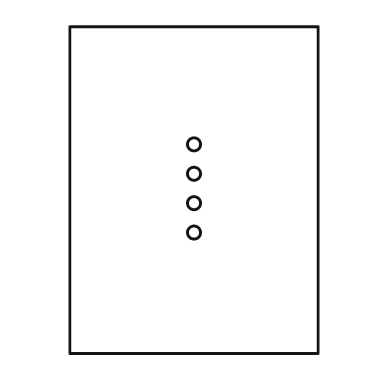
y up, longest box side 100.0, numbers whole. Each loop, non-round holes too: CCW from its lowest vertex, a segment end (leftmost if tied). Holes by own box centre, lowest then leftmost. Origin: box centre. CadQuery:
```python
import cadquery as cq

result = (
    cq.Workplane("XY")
    .moveTo(-38.0, -50.0)
    .lineTo(38.0, -50.0)
    .lineTo(38.0, 50.0)
    .lineTo(-38.0, 50.0)
    .close()
    .moveTo(0.0, -13.0)
    .circle(2.0)
    .moveTo(0.0, -4.0)
    .circle(2.0)
    .moveTo(0.0, 5.0)
    .circle(2.0)
    .moveTo(0.0, 14.0)
    .circle(2.0)
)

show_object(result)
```